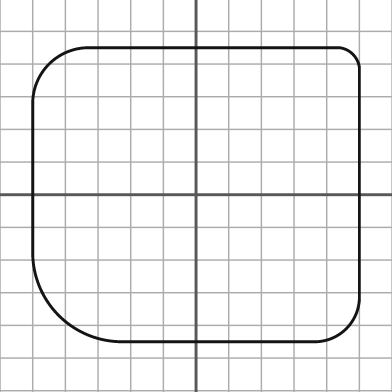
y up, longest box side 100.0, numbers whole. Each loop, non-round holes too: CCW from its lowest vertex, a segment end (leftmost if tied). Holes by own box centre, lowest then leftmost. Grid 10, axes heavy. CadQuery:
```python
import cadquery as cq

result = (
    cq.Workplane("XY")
    .moveTo(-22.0, -45.0)
    .lineTo(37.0, -45.0)
    .threePointArc((46.0, -41.0), (50.0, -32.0))
    .lineTo(50.0, 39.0)
    .threePointArc((48.0, 43.0), (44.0, 45.0))
    .lineTo(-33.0, 45.0)
    .threePointArc((-45.0, 40.0), (-50.0, 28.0))
    .lineTo(-50.0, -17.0)
    .threePointArc((-42.0, -37.0), (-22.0, -45.0))
    .close()
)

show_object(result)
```